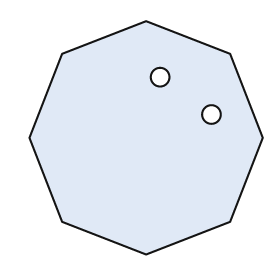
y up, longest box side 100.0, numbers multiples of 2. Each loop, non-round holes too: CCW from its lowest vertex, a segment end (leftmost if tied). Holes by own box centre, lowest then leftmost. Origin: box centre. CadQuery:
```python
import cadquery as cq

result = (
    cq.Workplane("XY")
    .moveTo(0.0, -50.0)
    .lineTo(36.0, -36.0)
    .lineTo(50.0, 0.0)
    .lineTo(36.0, 36.0)
    .lineTo(0.0, 50.0)
    .lineTo(-36.0, 36.0)
    .lineTo(-50.0, 0.0)
    .lineTo(-36.0, -36.0)
    .close()
    .moveTo(28.0, 10.0)
    .circle(4.0)
    .moveTo(6.0, 26.0)
    .circle(4.0)
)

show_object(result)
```